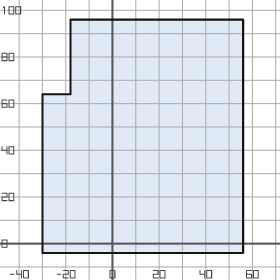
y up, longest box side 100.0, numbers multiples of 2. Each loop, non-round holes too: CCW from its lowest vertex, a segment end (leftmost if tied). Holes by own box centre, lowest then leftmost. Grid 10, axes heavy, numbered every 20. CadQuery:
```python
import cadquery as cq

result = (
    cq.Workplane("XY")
    .moveTo(-30.0, -4.0)
    .lineTo(56.0, -4.0)
    .lineTo(56.0, 96.0)
    .lineTo(-18.0, 96.0)
    .lineTo(-18.0, 64.0)
    .lineTo(-30.0, 64.0)
    .close()
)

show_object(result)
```